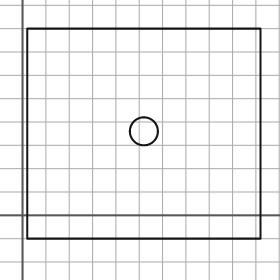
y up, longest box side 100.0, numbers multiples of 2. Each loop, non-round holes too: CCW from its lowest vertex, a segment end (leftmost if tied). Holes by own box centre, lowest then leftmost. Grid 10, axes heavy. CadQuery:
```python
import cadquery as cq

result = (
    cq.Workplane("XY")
    .moveTo(2.0, -10.0)
    .lineTo(102.0, -10.0)
    .lineTo(102.0, 80.0)
    .lineTo(2.0, 80.0)
    .close()
    .moveTo(52.0, 36.0)
    .circle(6.0)
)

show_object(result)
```